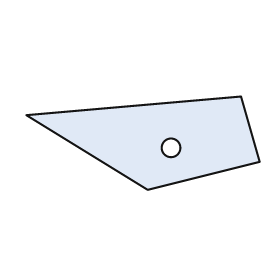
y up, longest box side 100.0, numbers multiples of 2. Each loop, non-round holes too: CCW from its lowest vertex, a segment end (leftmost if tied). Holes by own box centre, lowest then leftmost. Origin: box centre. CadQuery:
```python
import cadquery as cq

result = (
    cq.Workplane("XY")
    .moveTo(2.0, -20.0)
    .lineTo(50.0, -8.0)
    .lineTo(42.0, 20.0)
    .lineTo(-50.0, 12.0)
    .close()
    .moveTo(12.0, -2.0)
    .circle(4.0)
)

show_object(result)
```